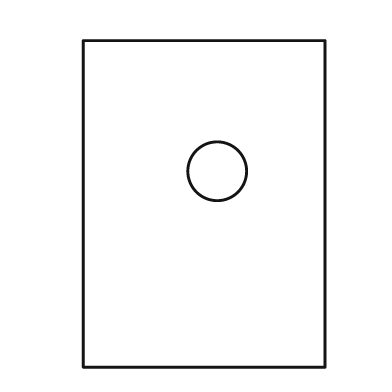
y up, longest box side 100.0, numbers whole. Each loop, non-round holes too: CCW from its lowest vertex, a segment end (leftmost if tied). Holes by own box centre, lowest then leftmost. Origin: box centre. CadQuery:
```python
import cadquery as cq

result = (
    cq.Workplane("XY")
    .moveTo(-37.0, -50.0)
    .lineTo(37.0, -50.0)
    .lineTo(37.0, 50.0)
    .lineTo(-37.0, 50.0)
    .close()
    .moveTo(4.0, 10.0)
    .circle(9.0)
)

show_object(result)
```